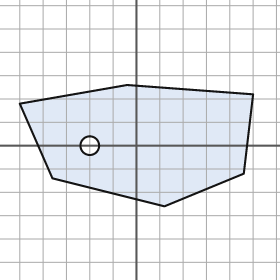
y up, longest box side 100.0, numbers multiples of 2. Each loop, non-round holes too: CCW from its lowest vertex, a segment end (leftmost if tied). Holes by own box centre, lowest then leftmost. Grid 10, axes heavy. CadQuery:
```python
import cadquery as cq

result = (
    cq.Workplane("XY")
    .moveTo(12.0, -26.0)
    .lineTo(46.0, -12.0)
    .lineTo(50.0, 22.0)
    .lineTo(-4.0, 26.0)
    .lineTo(-50.0, 18.0)
    .lineTo(-36.0, -14.0)
    .close()
    .moveTo(-20.0, 0.0)
    .circle(4.0)
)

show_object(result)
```